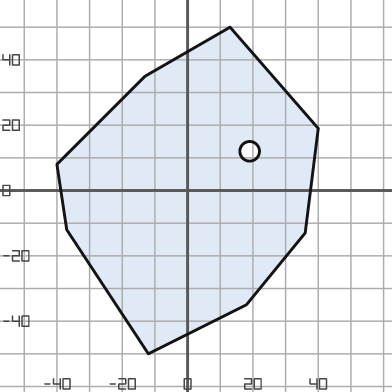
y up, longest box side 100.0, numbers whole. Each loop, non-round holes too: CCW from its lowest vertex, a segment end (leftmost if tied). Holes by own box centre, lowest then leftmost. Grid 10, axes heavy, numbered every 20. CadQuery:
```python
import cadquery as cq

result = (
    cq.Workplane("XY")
    .moveTo(-12.0, -50.0)
    .lineTo(18.0, -35.0)
    .lineTo(36.0, -13.0)
    .lineTo(40.0, 19.0)
    .lineTo(13.0, 50.0)
    .lineTo(-13.0, 35.0)
    .lineTo(-40.0, 8.0)
    .lineTo(-37.0, -12.0)
    .close()
    .moveTo(19.0, 12.0)
    .circle(3.0)
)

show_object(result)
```